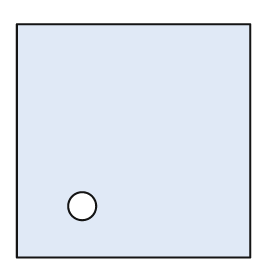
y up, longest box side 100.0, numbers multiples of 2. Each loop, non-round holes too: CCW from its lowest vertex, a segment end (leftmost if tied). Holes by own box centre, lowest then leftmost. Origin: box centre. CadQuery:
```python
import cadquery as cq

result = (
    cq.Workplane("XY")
    .moveTo(-50.0, -50.0)
    .lineTo(50.0, -50.0)
    .lineTo(50.0, 50.0)
    .lineTo(-50.0, 50.0)
    .close()
    .moveTo(-22.0, -28.0)
    .circle(6.0)
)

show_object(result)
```